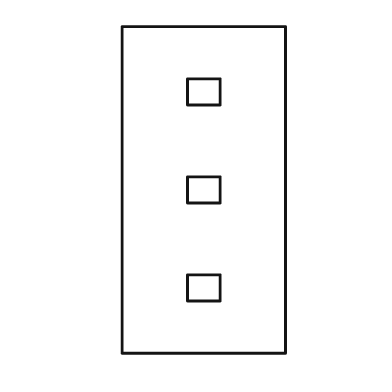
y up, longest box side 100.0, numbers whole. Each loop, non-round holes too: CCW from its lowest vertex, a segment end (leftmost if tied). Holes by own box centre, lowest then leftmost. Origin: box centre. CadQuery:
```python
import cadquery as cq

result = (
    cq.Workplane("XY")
    .moveTo(-25.0, -50.0)
    .lineTo(25.0, -50.0)
    .lineTo(25.0, 50.0)
    .lineTo(-25.0, 50.0)
    .close()
    .moveTo(-5.0, -34.0)
    .lineTo(5.0, -34.0)
    .lineTo(5.0, -26.0)
    .lineTo(-5.0, -26.0)
    .close()
    .moveTo(-5.0, -4.0)
    .lineTo(5.0, -4.0)
    .lineTo(5.0, 4.0)
    .lineTo(-5.0, 4.0)
    .close()
    .moveTo(-5.0, 26.0)
    .lineTo(5.0, 26.0)
    .lineTo(5.0, 34.0)
    .lineTo(-5.0, 34.0)
    .close()
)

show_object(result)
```